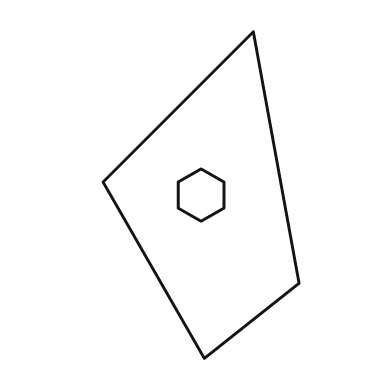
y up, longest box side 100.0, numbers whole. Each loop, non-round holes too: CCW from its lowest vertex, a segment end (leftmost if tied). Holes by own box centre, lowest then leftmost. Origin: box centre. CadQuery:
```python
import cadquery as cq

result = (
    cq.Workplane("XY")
    .moveTo(1.0, -50.0)
    .lineTo(30.0, -27.0)
    .lineTo(16.0, 50.0)
    .lineTo(-30.0, 4.0)
    .close()
    .moveTo(0.0, -8.0)
    .lineTo(7.0, -4.0)
    .lineTo(7.0, 4.0)
    .lineTo(0.0, 8.0)
    .lineTo(-7.0, 4.0)
    .lineTo(-7.0, -4.0)
    .close()
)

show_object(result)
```